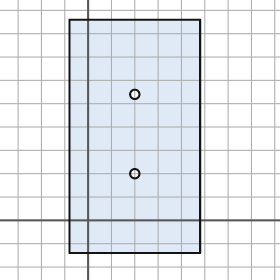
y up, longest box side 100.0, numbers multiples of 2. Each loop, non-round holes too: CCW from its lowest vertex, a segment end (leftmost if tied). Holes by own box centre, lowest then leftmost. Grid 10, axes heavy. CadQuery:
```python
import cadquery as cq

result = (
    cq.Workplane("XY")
    .moveTo(-8.0, -14.0)
    .lineTo(48.0, -14.0)
    .lineTo(48.0, 86.0)
    .lineTo(-8.0, 86.0)
    .close()
    .moveTo(20.0, 20.0)
    .circle(2.0)
    .moveTo(20.0, 54.0)
    .circle(2.0)
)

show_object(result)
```